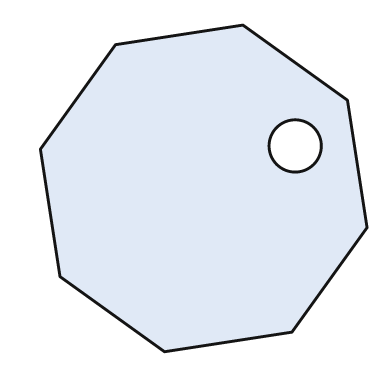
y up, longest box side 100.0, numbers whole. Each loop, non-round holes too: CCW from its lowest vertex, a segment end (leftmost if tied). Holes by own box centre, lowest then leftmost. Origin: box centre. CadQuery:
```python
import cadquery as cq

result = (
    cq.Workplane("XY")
    .moveTo(-12.0, -50.0)
    .lineTo(27.0, -44.0)
    .lineTo(50.0, -12.0)
    .lineTo(44.0, 27.0)
    .lineTo(12.0, 50.0)
    .lineTo(-27.0, 44.0)
    .lineTo(-50.0, 12.0)
    .lineTo(-44.0, -27.0)
    .close()
    .moveTo(28.0, 13.0)
    .circle(8.0)
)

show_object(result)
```